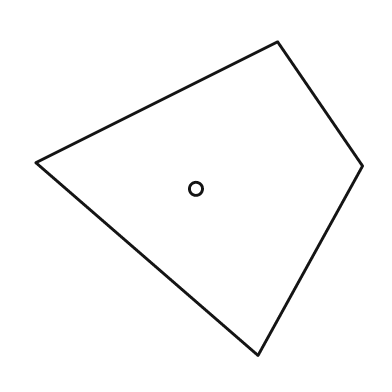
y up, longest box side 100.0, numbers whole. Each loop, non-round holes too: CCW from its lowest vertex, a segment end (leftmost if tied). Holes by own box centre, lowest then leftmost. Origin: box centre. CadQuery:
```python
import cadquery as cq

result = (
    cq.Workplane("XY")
    .moveTo(18.0, -48.0)
    .lineTo(50.0, 10.0)
    .lineTo(24.0, 48.0)
    .lineTo(-50.0, 11.0)
    .close()
    .moveTo(-1.0, 3.0)
    .circle(2.0)
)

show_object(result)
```